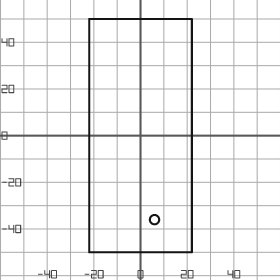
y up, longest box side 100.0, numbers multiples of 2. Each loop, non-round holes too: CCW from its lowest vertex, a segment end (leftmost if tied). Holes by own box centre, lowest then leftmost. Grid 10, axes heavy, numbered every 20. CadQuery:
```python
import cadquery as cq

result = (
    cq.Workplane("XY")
    .moveTo(-22.0, -50.0)
    .lineTo(22.0, -50.0)
    .lineTo(22.0, 50.0)
    .lineTo(-22.0, 50.0)
    .close()
    .moveTo(6.0, -36.0)
    .circle(2.0)
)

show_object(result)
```